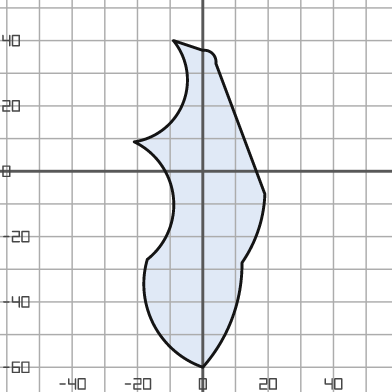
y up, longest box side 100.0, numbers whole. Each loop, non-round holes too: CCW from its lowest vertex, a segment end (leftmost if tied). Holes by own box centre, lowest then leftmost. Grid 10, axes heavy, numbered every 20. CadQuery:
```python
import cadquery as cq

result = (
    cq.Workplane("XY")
    .moveTo(0.0, -60.0)
    .threePointArc((9.0, -45.0), (12.0, -28.0))
    .threePointArc((17.0, -18.0), (19.0, -7.0))
    .lineTo(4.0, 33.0)
    .threePointArc((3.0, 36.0), (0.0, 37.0))
    .lineTo(-9.0, 40.0)
    .threePointArc((-6.0, 21.0), (-21.0, 9.0))
    .threePointArc((-9.0, -8.0), (-17.0, -27.0))
    .threePointArc((-15.0, -47.0), (0.0, -60.0))
    .close()
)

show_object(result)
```